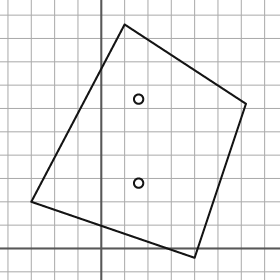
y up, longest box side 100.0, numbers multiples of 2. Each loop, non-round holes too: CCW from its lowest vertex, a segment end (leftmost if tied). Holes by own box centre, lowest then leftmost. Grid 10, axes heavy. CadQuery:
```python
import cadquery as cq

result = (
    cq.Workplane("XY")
    .moveTo(40.0, -4.0)
    .lineTo(62.0, 62.0)
    .lineTo(10.0, 96.0)
    .lineTo(-30.0, 20.0)
    .close()
    .moveTo(16.0, 28.0)
    .circle(2.0)
    .moveTo(16.0, 64.0)
    .circle(2.0)
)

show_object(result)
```